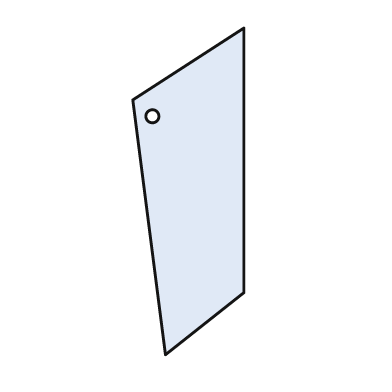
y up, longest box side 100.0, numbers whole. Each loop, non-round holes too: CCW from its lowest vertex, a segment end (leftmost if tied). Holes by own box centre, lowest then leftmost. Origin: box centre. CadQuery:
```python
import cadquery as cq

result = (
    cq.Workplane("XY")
    .moveTo(-7.0, -50.0)
    .lineTo(17.0, -31.0)
    .lineTo(17.0, 50.0)
    .lineTo(-17.0, 28.0)
    .close()
    .moveTo(-11.0, 23.0)
    .circle(2.0)
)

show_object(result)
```